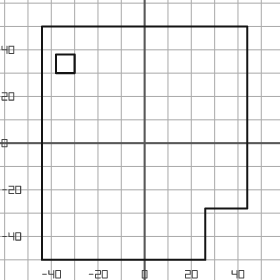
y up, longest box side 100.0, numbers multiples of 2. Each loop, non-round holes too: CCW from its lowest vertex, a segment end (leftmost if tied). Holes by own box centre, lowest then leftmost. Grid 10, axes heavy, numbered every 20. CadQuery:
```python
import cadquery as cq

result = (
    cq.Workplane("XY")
    .moveTo(-44.0, -50.0)
    .lineTo(26.0, -50.0)
    .lineTo(26.0, -28.0)
    .lineTo(44.0, -28.0)
    .lineTo(44.0, 50.0)
    .lineTo(-44.0, 50.0)
    .close()
    .moveTo(-38.0, 30.0)
    .lineTo(-30.0, 30.0)
    .lineTo(-30.0, 38.0)
    .lineTo(-38.0, 38.0)
    .close()
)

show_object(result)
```